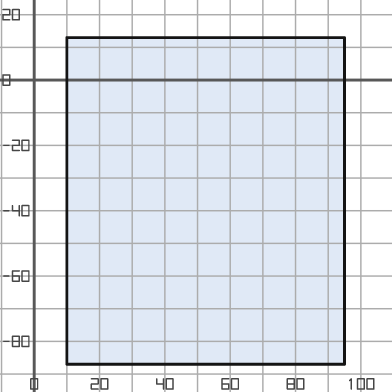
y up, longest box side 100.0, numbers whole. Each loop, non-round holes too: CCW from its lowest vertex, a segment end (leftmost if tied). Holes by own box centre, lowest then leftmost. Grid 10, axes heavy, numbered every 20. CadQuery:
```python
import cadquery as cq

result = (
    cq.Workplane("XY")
    .moveTo(10.0, -87.0)
    .lineTo(95.0, -87.0)
    .lineTo(95.0, 13.0)
    .lineTo(10.0, 13.0)
    .close()
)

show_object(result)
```